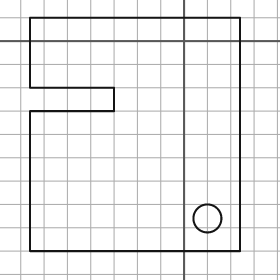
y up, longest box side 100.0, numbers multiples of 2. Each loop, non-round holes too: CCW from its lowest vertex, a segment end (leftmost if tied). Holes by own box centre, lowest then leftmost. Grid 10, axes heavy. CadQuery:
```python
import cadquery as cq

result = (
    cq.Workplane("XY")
    .moveTo(-66.0, -90.0)
    .lineTo(24.0, -90.0)
    .lineTo(24.0, 10.0)
    .lineTo(-66.0, 10.0)
    .lineTo(-66.0, -20.0)
    .lineTo(-30.0, -20.0)
    .lineTo(-30.0, -30.0)
    .lineTo(-66.0, -30.0)
    .close()
    .moveTo(10.0, -76.0)
    .circle(6.0)
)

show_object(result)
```